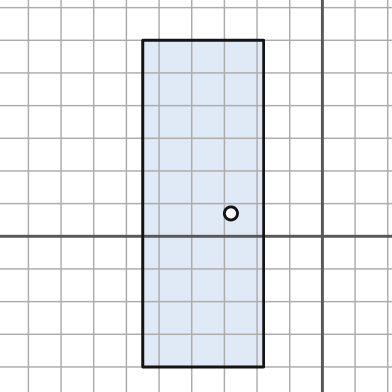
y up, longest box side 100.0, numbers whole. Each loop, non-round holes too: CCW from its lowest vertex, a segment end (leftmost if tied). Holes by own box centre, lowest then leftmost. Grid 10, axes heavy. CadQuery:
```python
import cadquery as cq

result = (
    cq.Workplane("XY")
    .moveTo(-55.0, -40.0)
    .lineTo(-18.0, -40.0)
    .lineTo(-18.0, 60.0)
    .lineTo(-55.0, 60.0)
    .close()
    .moveTo(-28.0, 7.0)
    .circle(2.0)
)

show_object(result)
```